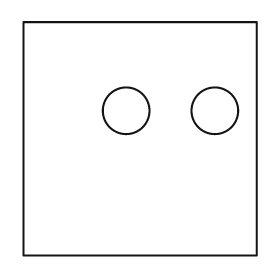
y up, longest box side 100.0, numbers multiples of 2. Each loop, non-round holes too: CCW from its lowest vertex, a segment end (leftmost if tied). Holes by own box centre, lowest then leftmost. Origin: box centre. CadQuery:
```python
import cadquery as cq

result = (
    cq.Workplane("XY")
    .moveTo(-50.0, -50.0)
    .lineTo(50.0, -50.0)
    .lineTo(50.0, 50.0)
    .lineTo(-50.0, 50.0)
    .close()
    .moveTo(-6.0, 12.0)
    .circle(10.0)
    .moveTo(32.0, 12.0)
    .circle(10.0)
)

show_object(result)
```